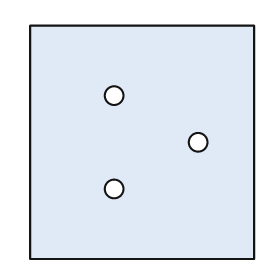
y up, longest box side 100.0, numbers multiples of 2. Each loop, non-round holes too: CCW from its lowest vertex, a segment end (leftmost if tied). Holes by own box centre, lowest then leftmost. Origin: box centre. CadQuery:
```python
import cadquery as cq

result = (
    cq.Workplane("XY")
    .moveTo(-48.0, -50.0)
    .lineTo(48.0, -50.0)
    .lineTo(48.0, 50.0)
    .lineTo(-48.0, 50.0)
    .close()
    .moveTo(-12.0, -20.0)
    .circle(4.0)
    .moveTo(24.0, 0.0)
    .circle(4.0)
    .moveTo(-12.0, 20.0)
    .circle(4.0)
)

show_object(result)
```